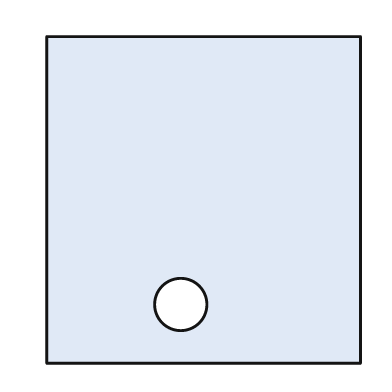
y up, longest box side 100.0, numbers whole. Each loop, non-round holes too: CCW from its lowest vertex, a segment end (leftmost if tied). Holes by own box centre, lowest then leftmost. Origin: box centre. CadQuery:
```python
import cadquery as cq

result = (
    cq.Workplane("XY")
    .moveTo(-48.0, -50.0)
    .lineTo(48.0, -50.0)
    .lineTo(48.0, 50.0)
    .lineTo(-48.0, 50.0)
    .close()
    .moveTo(-7.0, -32.0)
    .circle(8.0)
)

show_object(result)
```